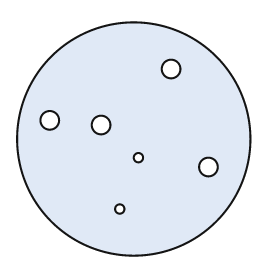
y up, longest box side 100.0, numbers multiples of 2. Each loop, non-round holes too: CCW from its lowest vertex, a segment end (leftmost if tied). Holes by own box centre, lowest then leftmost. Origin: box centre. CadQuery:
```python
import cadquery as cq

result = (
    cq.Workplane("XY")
    .moveTo(0.0, 0.0)
    .circle(50.0)
    .moveTo(-6.0, -30.0)
    .circle(2.0)
    .moveTo(32.0, -12.0)
    .circle(4.0)
    .moveTo(2.0, -8.0)
    .circle(2.0)
    .moveTo(-14.0, 6.0)
    .circle(4.0)
    .moveTo(-36.0, 8.0)
    .circle(4.0)
    .moveTo(16.0, 30.0)
    .circle(4.0)
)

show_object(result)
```